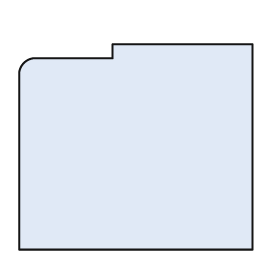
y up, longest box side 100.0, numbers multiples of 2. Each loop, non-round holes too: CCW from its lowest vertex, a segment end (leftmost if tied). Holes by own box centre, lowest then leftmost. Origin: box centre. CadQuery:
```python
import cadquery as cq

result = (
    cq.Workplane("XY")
    .moveTo(-50.0, -44.0)
    .lineTo(50.0, -44.0)
    .lineTo(50.0, 44.0)
    .lineTo(-10.0, 44.0)
    .lineTo(-10.0, 38.0)
    .lineTo(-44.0, 38.0)
    .threePointArc((-48.0, 36.0), (-50.0, 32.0))
    .close()
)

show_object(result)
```